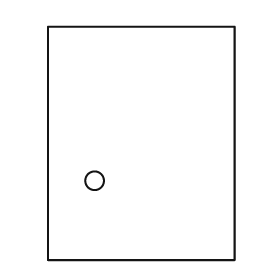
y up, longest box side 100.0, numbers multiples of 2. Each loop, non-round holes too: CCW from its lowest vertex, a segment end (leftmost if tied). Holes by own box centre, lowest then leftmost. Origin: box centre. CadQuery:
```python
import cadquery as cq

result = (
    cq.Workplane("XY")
    .moveTo(-40.0, -50.0)
    .lineTo(40.0, -50.0)
    .lineTo(40.0, 50.0)
    .lineTo(-40.0, 50.0)
    .close()
    .moveTo(-20.0, -16.0)
    .circle(4.0)
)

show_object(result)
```